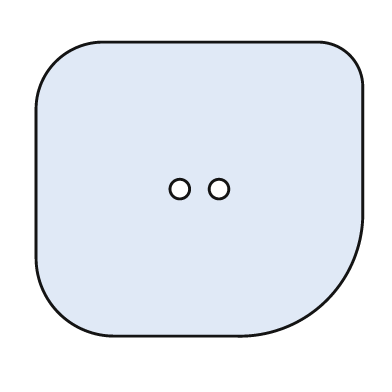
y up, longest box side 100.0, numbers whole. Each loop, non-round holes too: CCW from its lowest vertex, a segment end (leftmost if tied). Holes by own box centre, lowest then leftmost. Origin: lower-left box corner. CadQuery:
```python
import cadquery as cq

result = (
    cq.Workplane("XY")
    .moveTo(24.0, 0.0)
    .lineTo(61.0, 0.0)
    .threePointArc((89.0, 11.0), (100.0, 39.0))
    .lineTo(100.0, 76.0)
    .threePointArc((96.0, 86.0), (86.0, 90.0))
    .lineTo(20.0, 90.0)
    .threePointArc((6.0, 84.0), (0.0, 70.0))
    .lineTo(0.0, 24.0)
    .threePointArc((7.0, 7.0), (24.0, 0.0))
    .close()
    .moveTo(44.0, 45.0)
    .circle(3.0)
    .moveTo(56.0, 45.0)
    .circle(3.0)
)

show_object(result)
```